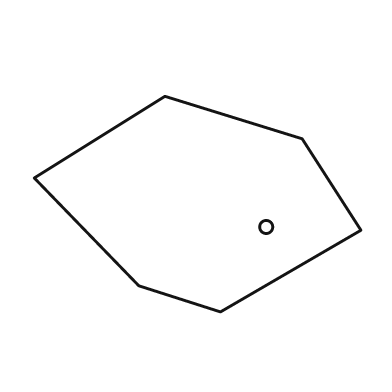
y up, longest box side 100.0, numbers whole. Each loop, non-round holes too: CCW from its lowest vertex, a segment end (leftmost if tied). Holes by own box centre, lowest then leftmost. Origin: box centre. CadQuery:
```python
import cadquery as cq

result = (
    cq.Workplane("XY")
    .moveTo(7.0, -33.0)
    .lineTo(50.0, -8.0)
    .lineTo(32.0, 20.0)
    .lineTo(-10.0, 33.0)
    .lineTo(-50.0, 8.0)
    .lineTo(-18.0, -25.0)
    .close()
    .moveTo(21.0, -7.0)
    .circle(2.0)
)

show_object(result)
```